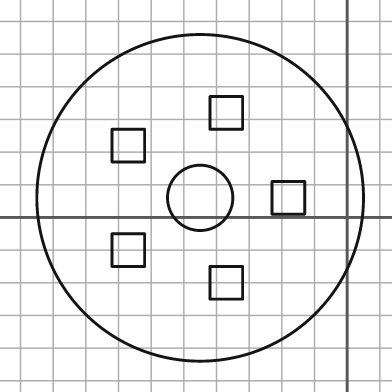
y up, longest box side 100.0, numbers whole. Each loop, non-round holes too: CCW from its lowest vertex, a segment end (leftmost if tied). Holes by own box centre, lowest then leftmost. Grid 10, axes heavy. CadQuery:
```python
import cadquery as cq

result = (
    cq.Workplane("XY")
    .moveTo(-45.0, 6.0)
    .circle(50.0)
    .moveTo(-42.0, -25.0)
    .lineTo(-32.0, -25.0)
    .lineTo(-32.0, -15.0)
    .lineTo(-42.0, -15.0)
    .close()
    .moveTo(-72.0, -15.0)
    .lineTo(-62.0, -15.0)
    .lineTo(-62.0, -5.0)
    .lineTo(-72.0, -5.0)
    .close()
    .moveTo(-45.0, 6.0)
    .circle(10.0)
    .moveTo(-23.0, 1.0)
    .lineTo(-13.0, 1.0)
    .lineTo(-13.0, 11.0)
    .lineTo(-23.0, 11.0)
    .close()
    .moveTo(-72.0, 17.0)
    .lineTo(-62.0, 17.0)
    .lineTo(-62.0, 27.0)
    .lineTo(-72.0, 27.0)
    .close()
    .moveTo(-42.0, 27.0)
    .lineTo(-32.0, 27.0)
    .lineTo(-32.0, 37.0)
    .lineTo(-42.0, 37.0)
    .close()
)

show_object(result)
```